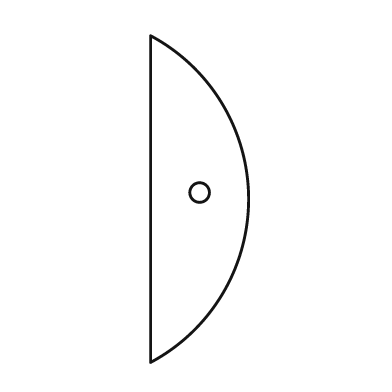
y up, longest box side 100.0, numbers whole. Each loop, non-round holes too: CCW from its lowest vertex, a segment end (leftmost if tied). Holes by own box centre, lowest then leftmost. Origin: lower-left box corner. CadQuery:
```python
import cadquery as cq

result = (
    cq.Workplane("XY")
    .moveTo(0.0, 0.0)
    .threePointArc((30.0, 50.0), (0.0, 100.0))
    .close()
    .moveTo(15.0, 52.0)
    .circle(3.0)
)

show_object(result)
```